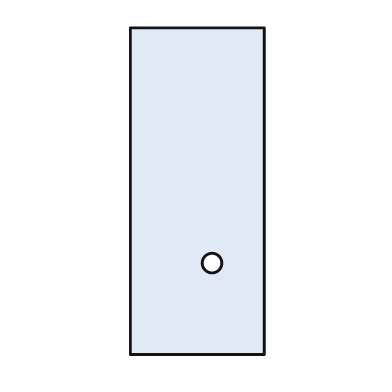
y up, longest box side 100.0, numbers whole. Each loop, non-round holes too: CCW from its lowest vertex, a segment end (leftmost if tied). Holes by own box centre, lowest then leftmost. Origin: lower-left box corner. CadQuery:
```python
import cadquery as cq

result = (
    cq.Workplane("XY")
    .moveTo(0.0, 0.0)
    .lineTo(41.0, 0.0)
    .lineTo(41.0, 100.0)
    .lineTo(0.0, 100.0)
    .close()
    .moveTo(25.0, 28.0)
    .circle(3.0)
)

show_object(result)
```